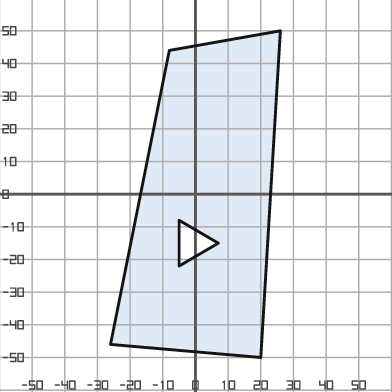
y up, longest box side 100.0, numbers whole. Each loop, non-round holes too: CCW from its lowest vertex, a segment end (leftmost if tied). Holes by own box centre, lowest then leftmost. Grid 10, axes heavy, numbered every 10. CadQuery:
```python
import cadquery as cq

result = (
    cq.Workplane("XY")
    .moveTo(20.0, -50.0)
    .lineTo(26.0, 50.0)
    .lineTo(-8.0, 44.0)
    .lineTo(-26.0, -46.0)
    .close()
    .moveTo(-5.0, -22.0)
    .lineTo(7.0, -15.0)
    .lineTo(-5.0, -8.0)
    .close()
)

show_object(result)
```